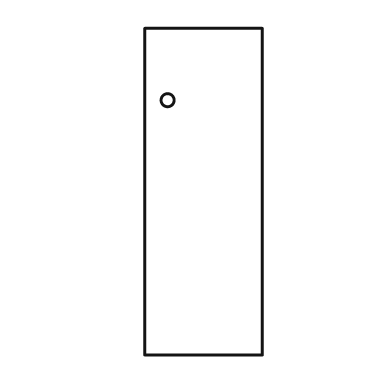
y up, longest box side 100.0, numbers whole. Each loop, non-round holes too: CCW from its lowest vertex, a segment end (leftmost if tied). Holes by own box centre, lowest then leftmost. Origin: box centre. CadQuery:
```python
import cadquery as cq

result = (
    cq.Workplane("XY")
    .moveTo(-18.0, -50.0)
    .lineTo(18.0, -50.0)
    .lineTo(18.0, 50.0)
    .lineTo(-18.0, 50.0)
    .close()
    .moveTo(-11.0, 28.0)
    .circle(2.0)
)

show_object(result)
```